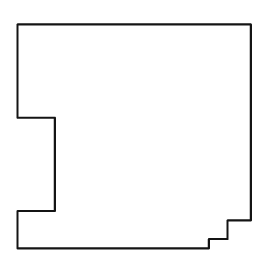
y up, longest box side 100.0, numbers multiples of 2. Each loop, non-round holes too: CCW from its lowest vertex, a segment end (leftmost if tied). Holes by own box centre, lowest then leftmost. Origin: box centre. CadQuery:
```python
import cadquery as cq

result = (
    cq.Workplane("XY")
    .moveTo(-50.0, -48.0)
    .lineTo(32.0, -48.0)
    .lineTo(32.0, -44.0)
    .lineTo(40.0, -44.0)
    .lineTo(40.0, -36.0)
    .lineTo(50.0, -36.0)
    .lineTo(50.0, 48.0)
    .lineTo(-50.0, 48.0)
    .lineTo(-50.0, 8.0)
    .lineTo(-34.0, 8.0)
    .lineTo(-34.0, -32.0)
    .lineTo(-50.0, -32.0)
    .close()
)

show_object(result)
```